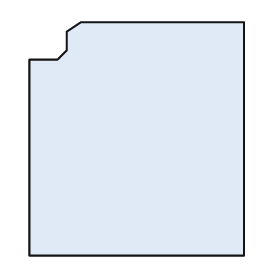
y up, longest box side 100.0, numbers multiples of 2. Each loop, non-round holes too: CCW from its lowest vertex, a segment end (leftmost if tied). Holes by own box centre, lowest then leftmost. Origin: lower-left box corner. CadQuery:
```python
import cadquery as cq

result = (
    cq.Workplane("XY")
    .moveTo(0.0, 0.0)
    .lineTo(92.0, 0.0)
    .lineTo(92.0, 100.0)
    .lineTo(22.0, 100.0)
    .lineTo(16.0, 96.0)
    .lineTo(16.0, 88.0)
    .lineTo(12.0, 84.0)
    .lineTo(0.0, 84.0)
    .close()
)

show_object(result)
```